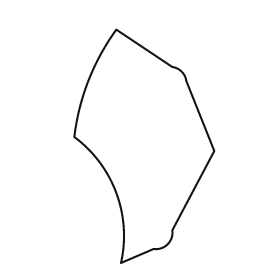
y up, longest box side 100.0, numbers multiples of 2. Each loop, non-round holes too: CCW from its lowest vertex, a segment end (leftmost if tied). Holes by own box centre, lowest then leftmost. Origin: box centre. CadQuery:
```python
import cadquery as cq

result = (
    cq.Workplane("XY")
    .moveTo(-10.0, -50.0)
    .lineTo(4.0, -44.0)
    .threePointArc((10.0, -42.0), (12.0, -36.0))
    .lineTo(30.0, -2.0)
    .lineTo(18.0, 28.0)
    .threePointArc((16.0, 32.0), (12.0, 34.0))
    .lineTo(-12.0, 50.0)
    .threePointArc((-24.0, 28.0), (-30.0, 4.0))
    .threePointArc((-12.0, -20.0), (-10.0, -50.0))
    .close()
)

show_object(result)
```